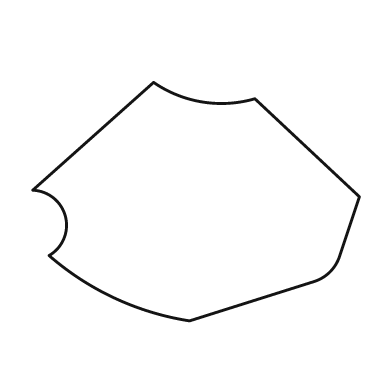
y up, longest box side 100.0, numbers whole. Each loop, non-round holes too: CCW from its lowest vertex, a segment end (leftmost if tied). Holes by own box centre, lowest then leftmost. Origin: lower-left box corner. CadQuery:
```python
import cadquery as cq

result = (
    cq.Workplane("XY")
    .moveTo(48.0, 0.0)
    .lineTo(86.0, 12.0)
    .threePointArc((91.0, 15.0), (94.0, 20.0))
    .lineTo(100.0, 38.0)
    .lineTo(68.0, 68.0)
    .threePointArc((52.0, 67.0), (37.0, 73.0))
    .lineTo(0.0, 40.0)
    .threePointArc((10.0, 32.0), (5.0, 20.0))
    .threePointArc((25.0, 7.0), (48.0, 0.0))
    .close()
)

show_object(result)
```